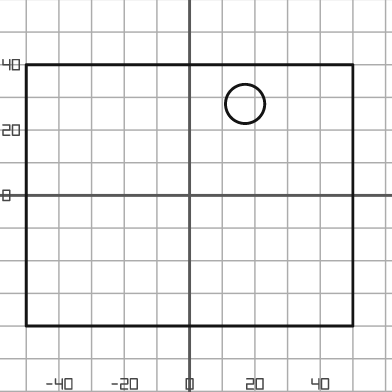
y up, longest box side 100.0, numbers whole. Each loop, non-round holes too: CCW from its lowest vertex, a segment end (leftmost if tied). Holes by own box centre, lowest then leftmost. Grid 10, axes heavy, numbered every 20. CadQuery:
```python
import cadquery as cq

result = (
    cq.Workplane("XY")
    .moveTo(-50.0, -40.0)
    .lineTo(50.0, -40.0)
    .lineTo(50.0, 40.0)
    .lineTo(-50.0, 40.0)
    .close()
    .moveTo(17.0, 28.0)
    .circle(6.0)
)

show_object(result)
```